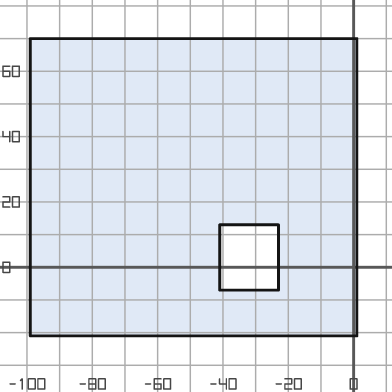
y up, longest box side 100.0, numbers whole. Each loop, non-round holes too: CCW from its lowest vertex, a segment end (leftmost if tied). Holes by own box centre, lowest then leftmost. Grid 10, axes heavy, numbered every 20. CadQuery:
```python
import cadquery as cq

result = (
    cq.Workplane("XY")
    .moveTo(-99.0, -21.0)
    .lineTo(1.0, -21.0)
    .lineTo(1.0, 70.0)
    .lineTo(-99.0, 70.0)
    .close()
    .moveTo(-41.0, -7.0)
    .lineTo(-23.0, -7.0)
    .lineTo(-23.0, 13.0)
    .lineTo(-41.0, 13.0)
    .close()
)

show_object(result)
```